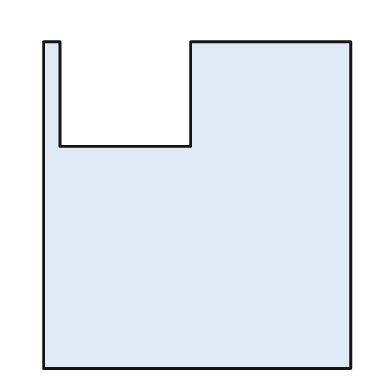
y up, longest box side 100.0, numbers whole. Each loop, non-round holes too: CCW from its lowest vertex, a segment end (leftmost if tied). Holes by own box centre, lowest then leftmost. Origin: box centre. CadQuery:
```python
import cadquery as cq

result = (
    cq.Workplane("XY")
    .moveTo(-47.0, -50.0)
    .lineTo(47.0, -50.0)
    .lineTo(47.0, 50.0)
    .lineTo(-2.0, 50.0)
    .lineTo(-2.0, 18.0)
    .lineTo(-42.0, 18.0)
    .lineTo(-42.0, 50.0)
    .lineTo(-47.0, 50.0)
    .close()
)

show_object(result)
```